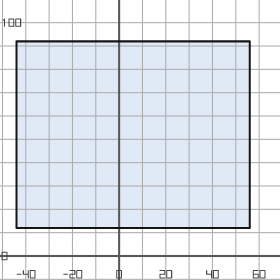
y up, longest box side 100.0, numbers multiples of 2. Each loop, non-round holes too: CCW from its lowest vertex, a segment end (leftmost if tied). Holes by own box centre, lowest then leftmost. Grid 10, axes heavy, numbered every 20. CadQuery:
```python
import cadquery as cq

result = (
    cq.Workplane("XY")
    .moveTo(-44.0, 12.0)
    .lineTo(56.0, 12.0)
    .lineTo(56.0, 92.0)
    .lineTo(-44.0, 92.0)
    .close()
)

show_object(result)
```